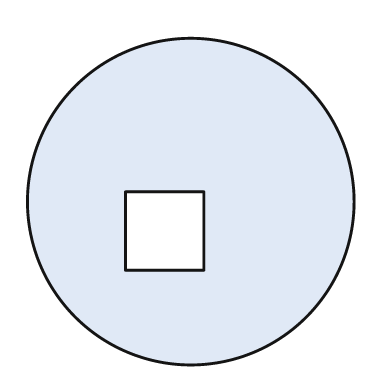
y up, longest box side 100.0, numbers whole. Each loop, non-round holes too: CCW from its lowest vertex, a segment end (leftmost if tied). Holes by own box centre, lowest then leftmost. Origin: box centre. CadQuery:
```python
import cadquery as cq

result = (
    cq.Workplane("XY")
    .moveTo(0.0, 0.0)
    .circle(50.0)
    .moveTo(-20.0, -21.0)
    .lineTo(4.0, -21.0)
    .lineTo(4.0, 3.0)
    .lineTo(-20.0, 3.0)
    .close()
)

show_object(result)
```